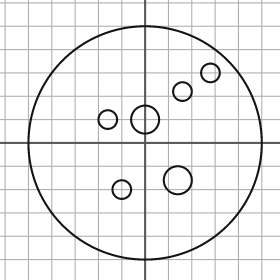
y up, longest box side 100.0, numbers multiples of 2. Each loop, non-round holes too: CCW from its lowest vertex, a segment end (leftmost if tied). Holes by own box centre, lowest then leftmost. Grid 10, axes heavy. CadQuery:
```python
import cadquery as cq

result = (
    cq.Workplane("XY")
    .moveTo(0.0, 0.0)
    .circle(50.0)
    .moveTo(-10.0, -20.0)
    .circle(4.0)
    .moveTo(14.0, -16.0)
    .circle(6.0)
    .moveTo(-16.0, 10.0)
    .circle(4.0)
    .moveTo(0.0, 10.0)
    .circle(6.0)
    .moveTo(16.0, 22.0)
    .circle(4.0)
    .moveTo(28.0, 30.0)
    .circle(4.0)
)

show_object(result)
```